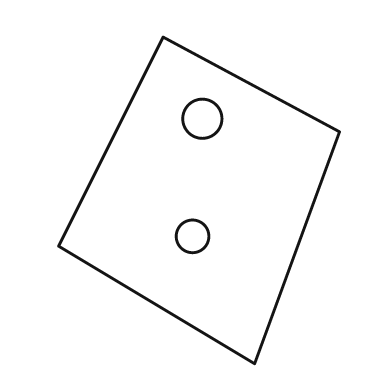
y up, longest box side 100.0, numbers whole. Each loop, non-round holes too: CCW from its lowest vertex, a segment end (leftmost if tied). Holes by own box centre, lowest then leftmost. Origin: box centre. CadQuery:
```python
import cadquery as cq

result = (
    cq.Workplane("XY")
    .moveTo(17.0, -50.0)
    .lineTo(43.0, 21.0)
    .lineTo(-11.0, 50.0)
    .lineTo(-43.0, -14.0)
    .close()
    .moveTo(-2.0, -11.0)
    .circle(5.0)
    .moveTo(1.0, 25.0)
    .circle(6.0)
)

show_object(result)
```